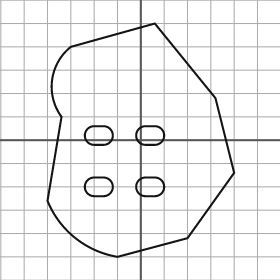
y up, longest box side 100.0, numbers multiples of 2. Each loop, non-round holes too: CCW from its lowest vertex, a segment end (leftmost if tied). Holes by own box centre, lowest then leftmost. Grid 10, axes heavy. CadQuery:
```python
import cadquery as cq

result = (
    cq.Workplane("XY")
    .moveTo(-10.0, -50.0)
    .lineTo(20.0, -42.0)
    .lineTo(40.0, -14.0)
    .lineTo(32.0, 18.0)
    .lineTo(6.0, 50.0)
    .lineTo(-30.0, 40.0)
    .threePointArc((-38.0, 26.0), (-34.0, 10.0))
    .lineTo(-40.0, -26.0)
    .threePointArc((-28.0, -42.0), (-10.0, -50.0))
    .close()
    .moveTo(-20.0, -24.0)
    .lineTo(-16.0, -24.0)
    .threePointArc((-12.0, -20.0), (-16.0, -16.0))
    .lineTo(-20.0, -16.0)
    .threePointArc((-24.0, -20.0), (-20.0, -24.0))
    .close()
    .moveTo(2.0, -24.0)
    .lineTo(6.0, -24.0)
    .threePointArc((10.0, -20.0), (6.0, -16.0))
    .lineTo(2.0, -16.0)
    .threePointArc((-2.0, -20.0), (2.0, -24.0))
    .close()
    .moveTo(-20.0, -2.0)
    .lineTo(-16.0, -2.0)
    .threePointArc((-12.0, 2.0), (-16.0, 6.0))
    .lineTo(-20.0, 6.0)
    .threePointArc((-24.0, 2.0), (-20.0, -2.0))
    .close()
    .moveTo(2.0, -2.0)
    .lineTo(6.0, -2.0)
    .threePointArc((10.0, 2.0), (6.0, 6.0))
    .lineTo(2.0, 6.0)
    .threePointArc((-2.0, 2.0), (2.0, -2.0))
    .close()
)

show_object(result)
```